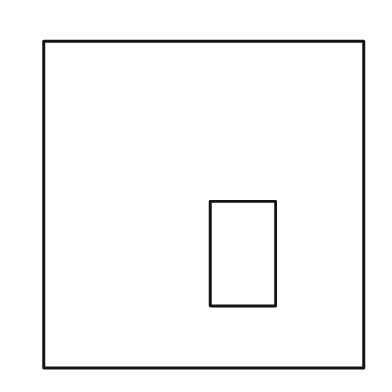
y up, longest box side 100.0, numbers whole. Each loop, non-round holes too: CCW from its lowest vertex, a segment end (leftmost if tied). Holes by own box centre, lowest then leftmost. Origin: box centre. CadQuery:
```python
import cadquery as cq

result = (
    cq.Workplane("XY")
    .moveTo(-49.0, -50.0)
    .lineTo(49.0, -50.0)
    .lineTo(49.0, 50.0)
    .lineTo(-49.0, 50.0)
    .close()
    .moveTo(2.0, -31.0)
    .lineTo(22.0, -31.0)
    .lineTo(22.0, 1.0)
    .lineTo(2.0, 1.0)
    .close()
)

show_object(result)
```